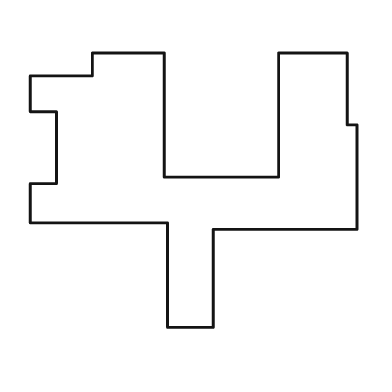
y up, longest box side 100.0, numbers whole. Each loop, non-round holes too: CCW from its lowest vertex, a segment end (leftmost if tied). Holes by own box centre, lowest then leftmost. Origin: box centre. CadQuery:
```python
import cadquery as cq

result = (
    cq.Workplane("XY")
    .moveTo(-8.0, -42.0)
    .lineTo(6.0, -42.0)
    .lineTo(6.0, -12.0)
    .lineTo(50.0, -12.0)
    .lineTo(50.0, 20.0)
    .lineTo(47.0, 20.0)
    .lineTo(47.0, 42.0)
    .lineTo(26.0, 42.0)
    .lineTo(26.0, 4.0)
    .lineTo(-9.0, 4.0)
    .lineTo(-9.0, 42.0)
    .lineTo(-31.0, 42.0)
    .lineTo(-31.0, 35.0)
    .lineTo(-50.0, 35.0)
    .lineTo(-50.0, 24.0)
    .lineTo(-42.0, 24.0)
    .lineTo(-42.0, 2.0)
    .lineTo(-50.0, 2.0)
    .lineTo(-50.0, -10.0)
    .lineTo(-8.0, -10.0)
    .close()
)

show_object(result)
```